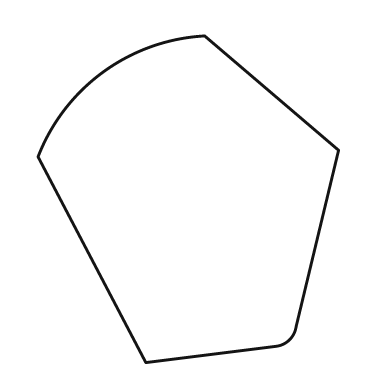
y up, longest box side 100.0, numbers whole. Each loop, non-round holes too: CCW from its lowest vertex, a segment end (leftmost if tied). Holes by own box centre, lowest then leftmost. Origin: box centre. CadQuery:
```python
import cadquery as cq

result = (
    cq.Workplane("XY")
    .moveTo(-13.0, -50.0)
    .lineTo(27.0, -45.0)
    .threePointArc((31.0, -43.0), (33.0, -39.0))
    .lineTo(46.0, 15.0)
    .lineTo(5.0, 50.0)
    .threePointArc((-26.0, 39.0), (-46.0, 13.0))
    .close()
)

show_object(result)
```